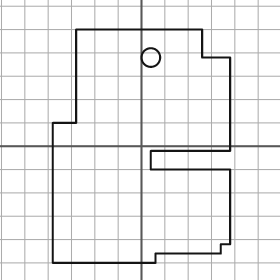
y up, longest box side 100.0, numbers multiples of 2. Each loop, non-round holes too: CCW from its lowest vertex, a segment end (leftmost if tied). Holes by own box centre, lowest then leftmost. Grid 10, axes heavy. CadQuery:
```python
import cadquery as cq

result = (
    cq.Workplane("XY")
    .moveTo(-38.0, -50.0)
    .lineTo(6.0, -50.0)
    .lineTo(6.0, -46.0)
    .lineTo(34.0, -46.0)
    .lineTo(34.0, -42.0)
    .lineTo(38.0, -42.0)
    .lineTo(38.0, -10.0)
    .lineTo(4.0, -10.0)
    .lineTo(4.0, -2.0)
    .lineTo(38.0, -2.0)
    .lineTo(38.0, 38.0)
    .lineTo(26.0, 38.0)
    .lineTo(26.0, 50.0)
    .lineTo(-28.0, 50.0)
    .lineTo(-28.0, 10.0)
    .lineTo(-38.0, 10.0)
    .close()
    .moveTo(4.0, 38.0)
    .circle(4.0)
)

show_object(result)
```